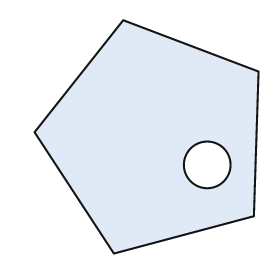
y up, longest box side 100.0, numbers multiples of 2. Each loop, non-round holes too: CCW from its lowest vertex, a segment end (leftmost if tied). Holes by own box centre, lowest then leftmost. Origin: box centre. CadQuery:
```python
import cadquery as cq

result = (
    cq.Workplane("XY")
    .moveTo(-14.0, -50.0)
    .lineTo(46.0, -34.0)
    .lineTo(48.0, 28.0)
    .lineTo(-10.0, 50.0)
    .lineTo(-48.0, 2.0)
    .close()
    .moveTo(26.0, -12.0)
    .circle(10.0)
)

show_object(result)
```